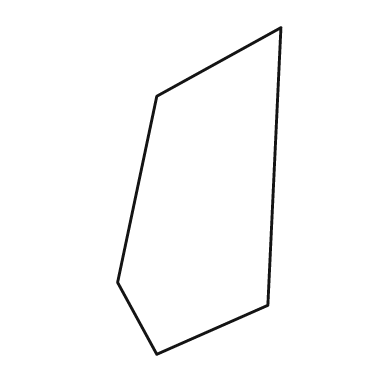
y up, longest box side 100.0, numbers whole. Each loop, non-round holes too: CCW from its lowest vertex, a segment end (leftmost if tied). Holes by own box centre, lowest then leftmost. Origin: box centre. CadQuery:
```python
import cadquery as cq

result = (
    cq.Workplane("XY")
    .moveTo(-13.0, -50.0)
    .lineTo(21.0, -35.0)
    .lineTo(25.0, 50.0)
    .lineTo(-13.0, 29.0)
    .lineTo(-25.0, -28.0)
    .close()
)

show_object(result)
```